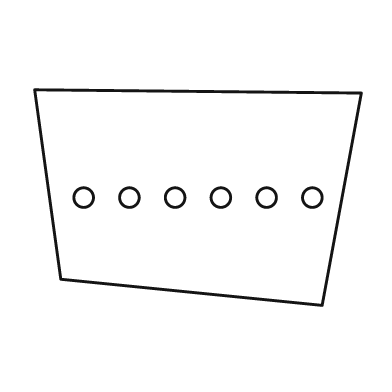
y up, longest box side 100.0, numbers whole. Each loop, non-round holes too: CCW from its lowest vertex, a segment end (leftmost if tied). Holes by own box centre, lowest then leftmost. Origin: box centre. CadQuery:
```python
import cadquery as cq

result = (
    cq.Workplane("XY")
    .moveTo(38.0, -33.0)
    .lineTo(50.0, 32.0)
    .lineTo(-50.0, 33.0)
    .lineTo(-42.0, -25.0)
    .close()
    .moveTo(-35.0, 0.0)
    .circle(3.0)
    .moveTo(-21.0, 0.0)
    .circle(3.0)
    .moveTo(-7.0, 0.0)
    .circle(3.0)
    .moveTo(7.0, 0.0)
    .circle(3.0)
    .moveTo(21.0, 0.0)
    .circle(3.0)
    .moveTo(35.0, 0.0)
    .circle(3.0)
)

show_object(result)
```